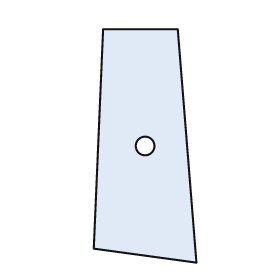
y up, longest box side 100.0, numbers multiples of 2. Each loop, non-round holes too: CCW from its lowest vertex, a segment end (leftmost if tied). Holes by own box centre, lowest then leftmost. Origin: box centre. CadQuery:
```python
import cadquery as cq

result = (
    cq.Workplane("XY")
    .moveTo(22.0, -50.0)
    .lineTo(14.0, 50.0)
    .lineTo(-18.0, 50.0)
    .lineTo(-22.0, -44.0)
    .close()
    .moveTo(0.0, 0.0)
    .circle(4.0)
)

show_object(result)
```